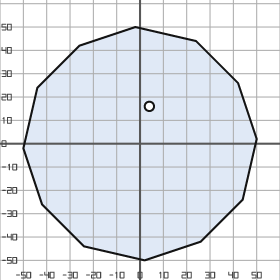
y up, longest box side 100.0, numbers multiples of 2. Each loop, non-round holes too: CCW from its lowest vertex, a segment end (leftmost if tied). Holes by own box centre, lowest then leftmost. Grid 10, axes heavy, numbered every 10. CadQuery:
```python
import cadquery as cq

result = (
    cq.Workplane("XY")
    .moveTo(2.0, -50.0)
    .lineTo(26.0, -42.0)
    .lineTo(44.0, -24.0)
    .lineTo(50.0, 2.0)
    .lineTo(42.0, 26.0)
    .lineTo(24.0, 44.0)
    .lineTo(-2.0, 50.0)
    .lineTo(-26.0, 42.0)
    .lineTo(-44.0, 24.0)
    .lineTo(-50.0, -2.0)
    .lineTo(-42.0, -26.0)
    .lineTo(-24.0, -44.0)
    .close()
    .moveTo(4.0, 16.0)
    .circle(2.0)
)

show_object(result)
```